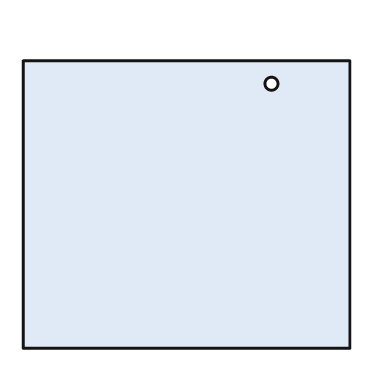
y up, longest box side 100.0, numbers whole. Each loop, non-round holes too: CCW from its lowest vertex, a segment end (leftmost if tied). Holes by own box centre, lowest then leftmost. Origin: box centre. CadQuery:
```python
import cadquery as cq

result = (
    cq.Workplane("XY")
    .moveTo(-50.0, -44.0)
    .lineTo(50.0, -44.0)
    .lineTo(50.0, 44.0)
    .lineTo(-50.0, 44.0)
    .close()
    .moveTo(26.0, 37.0)
    .circle(2.0)
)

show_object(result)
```